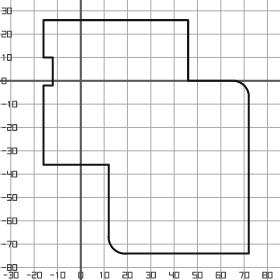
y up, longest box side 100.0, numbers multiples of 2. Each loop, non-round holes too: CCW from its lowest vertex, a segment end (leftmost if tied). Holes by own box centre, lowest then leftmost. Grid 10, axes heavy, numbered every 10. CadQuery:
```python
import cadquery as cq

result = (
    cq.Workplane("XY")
    .moveTo(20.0, -74.0)
    .lineTo(72.0, -74.0)
    .lineTo(72.0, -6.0)
    .threePointArc((70.0, -2.0), (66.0, 0.0))
    .lineTo(46.0, 0.0)
    .lineTo(46.0, 26.0)
    .lineTo(-16.0, 26.0)
    .lineTo(-16.0, 10.0)
    .lineTo(-12.0, 10.0)
    .lineTo(-12.0, -2.0)
    .lineTo(-16.0, -2.0)
    .lineTo(-16.0, -36.0)
    .lineTo(12.0, -36.0)
    .lineTo(12.0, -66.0)
    .threePointArc((14.0, -72.0), (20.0, -74.0))
    .close()
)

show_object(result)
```